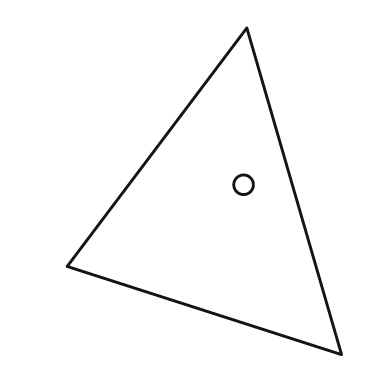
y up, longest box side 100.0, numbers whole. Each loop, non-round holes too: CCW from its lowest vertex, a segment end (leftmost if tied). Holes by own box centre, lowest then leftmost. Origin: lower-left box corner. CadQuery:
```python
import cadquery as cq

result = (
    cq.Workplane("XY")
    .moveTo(84.0, 0.0)
    .lineTo(55.0, 100.0)
    .lineTo(0.0, 27.0)
    .close()
    .moveTo(54.0, 52.0)
    .circle(3.0)
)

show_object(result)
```